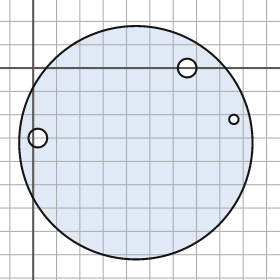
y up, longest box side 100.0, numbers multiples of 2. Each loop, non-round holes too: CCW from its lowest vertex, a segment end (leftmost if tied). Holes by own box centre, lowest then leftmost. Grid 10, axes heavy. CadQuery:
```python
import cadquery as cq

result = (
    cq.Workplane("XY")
    .moveTo(44.0, -32.0)
    .circle(50.0)
    .moveTo(2.0, -30.0)
    .circle(4.0)
    .moveTo(86.0, -22.0)
    .circle(2.0)
    .moveTo(66.0, 0.0)
    .circle(4.0)
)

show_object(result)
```